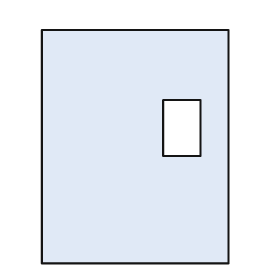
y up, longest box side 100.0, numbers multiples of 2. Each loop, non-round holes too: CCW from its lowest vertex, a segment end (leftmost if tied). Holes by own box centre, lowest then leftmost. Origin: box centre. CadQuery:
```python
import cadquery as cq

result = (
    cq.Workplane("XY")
    .moveTo(-40.0, -50.0)
    .lineTo(40.0, -50.0)
    .lineTo(40.0, 50.0)
    .lineTo(-40.0, 50.0)
    .close()
    .moveTo(12.0, -4.0)
    .lineTo(28.0, -4.0)
    .lineTo(28.0, 20.0)
    .lineTo(12.0, 20.0)
    .close()
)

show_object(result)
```